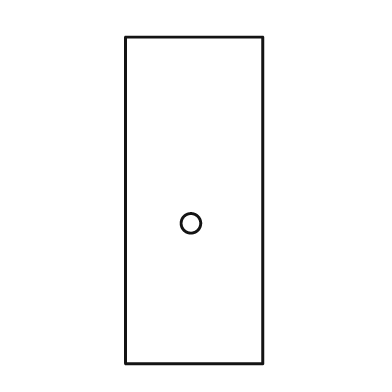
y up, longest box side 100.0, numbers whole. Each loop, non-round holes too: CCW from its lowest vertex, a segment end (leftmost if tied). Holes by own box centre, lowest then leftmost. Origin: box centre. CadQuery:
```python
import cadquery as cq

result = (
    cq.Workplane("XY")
    .moveTo(-21.0, -50.0)
    .lineTo(21.0, -50.0)
    .lineTo(21.0, 50.0)
    .lineTo(-21.0, 50.0)
    .close()
    .moveTo(-1.0, -7.0)
    .circle(3.0)
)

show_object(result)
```